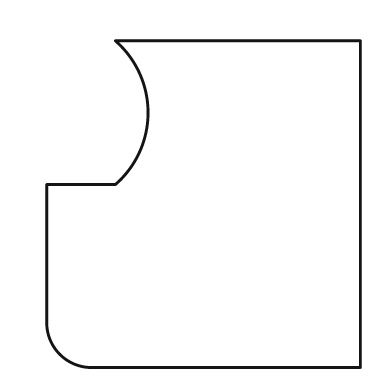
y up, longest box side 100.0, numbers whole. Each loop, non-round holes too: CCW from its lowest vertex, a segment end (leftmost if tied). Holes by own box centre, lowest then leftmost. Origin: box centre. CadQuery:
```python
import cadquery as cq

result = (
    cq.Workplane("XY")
    .moveTo(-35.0, -50.0)
    .lineTo(48.0, -50.0)
    .lineTo(48.0, 50.0)
    .lineTo(-27.0, 50.0)
    .threePointArc((-17.0, 28.0), (-27.0, 6.0))
    .lineTo(-48.0, 6.0)
    .lineTo(-48.0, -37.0)
    .threePointArc((-44.0, -46.0), (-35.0, -50.0))
    .close()
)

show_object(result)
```